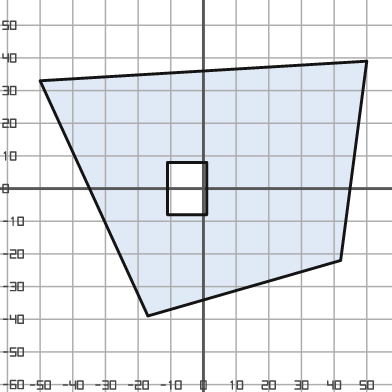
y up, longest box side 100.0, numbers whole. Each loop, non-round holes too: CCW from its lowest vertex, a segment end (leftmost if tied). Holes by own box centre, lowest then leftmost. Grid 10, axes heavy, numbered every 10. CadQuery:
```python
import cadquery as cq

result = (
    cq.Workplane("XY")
    .moveTo(-17.0, -39.0)
    .lineTo(42.0, -22.0)
    .lineTo(50.0, 39.0)
    .lineTo(-50.0, 33.0)
    .close()
    .moveTo(-11.0, -8.0)
    .lineTo(1.0, -8.0)
    .lineTo(1.0, 8.0)
    .lineTo(-11.0, 8.0)
    .close()
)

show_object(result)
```